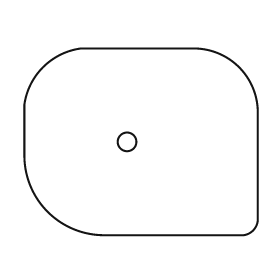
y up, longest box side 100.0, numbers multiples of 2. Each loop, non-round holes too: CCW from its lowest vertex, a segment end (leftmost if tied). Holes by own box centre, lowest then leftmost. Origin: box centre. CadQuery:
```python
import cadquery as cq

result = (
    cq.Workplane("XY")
    .moveTo(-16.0, -40.0)
    .lineTo(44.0, -40.0)
    .threePointArc((48.0, -38.0), (50.0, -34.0))
    .lineTo(50.0, 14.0)
    .threePointArc((42.0, 32.0), (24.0, 40.0))
    .lineTo(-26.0, 40.0)
    .threePointArc((-42.0, 32.0), (-50.0, 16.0))
    .lineTo(-50.0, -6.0)
    .threePointArc((-40.0, -30.0), (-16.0, -40.0))
    .close()
    .moveTo(-6.0, 0.0)
    .circle(4.0)
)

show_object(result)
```